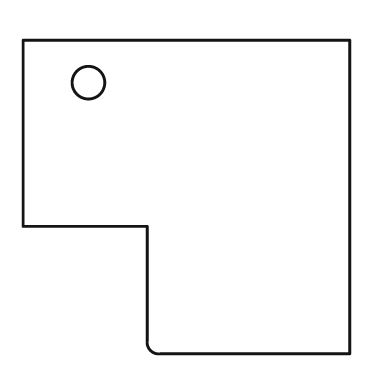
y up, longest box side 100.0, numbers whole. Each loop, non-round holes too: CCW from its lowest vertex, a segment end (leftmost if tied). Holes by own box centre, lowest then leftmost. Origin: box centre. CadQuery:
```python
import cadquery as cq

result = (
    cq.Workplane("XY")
    .moveTo(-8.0, -48.0)
    .lineTo(50.0, -48.0)
    .lineTo(50.0, 48.0)
    .lineTo(-50.0, 48.0)
    .lineTo(-50.0, -9.0)
    .lineTo(-12.0, -9.0)
    .lineTo(-12.0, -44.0)
    .threePointArc((-11.0, -47.0), (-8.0, -48.0))
    .close()
    .moveTo(-30.0, 35.0)
    .circle(5.0)
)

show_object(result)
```